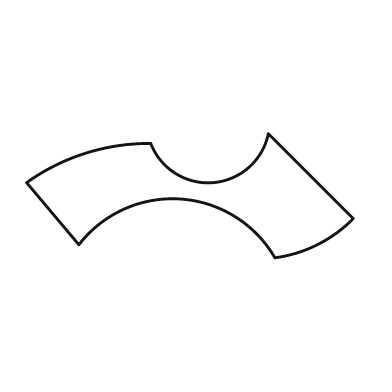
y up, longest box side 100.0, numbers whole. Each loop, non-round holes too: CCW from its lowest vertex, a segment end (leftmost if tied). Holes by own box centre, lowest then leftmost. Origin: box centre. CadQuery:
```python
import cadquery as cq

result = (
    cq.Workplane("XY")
    .moveTo(26.0, -19.0)
    .threePointArc((39.0, -15.0), (50.0, -7.0))
    .lineTo(24.0, 19.0)
    .threePointArc((7.0, 4.0), (-12.0, 16.0))
    .threePointArc((-32.0, 13.0), (-50.0, 4.0))
    .lineTo(-34.0, -15.0)
    .threePointArc((-3.0, -1.0), (26.0, -19.0))
    .close()
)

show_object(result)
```